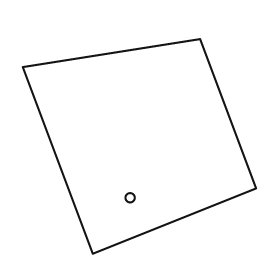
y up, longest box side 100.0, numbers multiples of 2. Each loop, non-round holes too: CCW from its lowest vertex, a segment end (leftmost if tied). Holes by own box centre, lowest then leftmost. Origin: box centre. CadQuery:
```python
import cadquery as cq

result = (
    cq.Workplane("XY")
    .moveTo(-20.0, -46.0)
    .lineTo(50.0, -18.0)
    .lineTo(26.0, 46.0)
    .lineTo(-50.0, 34.0)
    .close()
    .moveTo(-4.0, -22.0)
    .circle(2.0)
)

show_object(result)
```